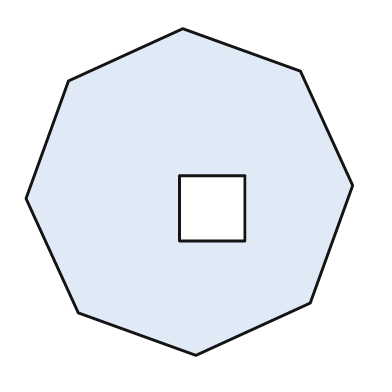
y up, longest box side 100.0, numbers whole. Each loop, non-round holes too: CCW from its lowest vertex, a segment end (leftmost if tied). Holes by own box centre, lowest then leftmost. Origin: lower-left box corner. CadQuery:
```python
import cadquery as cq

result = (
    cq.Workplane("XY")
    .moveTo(52.0, 0.0)
    .lineTo(87.0, 16.0)
    .lineTo(100.0, 52.0)
    .lineTo(84.0, 87.0)
    .lineTo(48.0, 100.0)
    .lineTo(13.0, 84.0)
    .lineTo(0.0, 48.0)
    .lineTo(16.0, 13.0)
    .close()
    .moveTo(47.0, 35.0)
    .lineTo(67.0, 35.0)
    .lineTo(67.0, 55.0)
    .lineTo(47.0, 55.0)
    .close()
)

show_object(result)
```